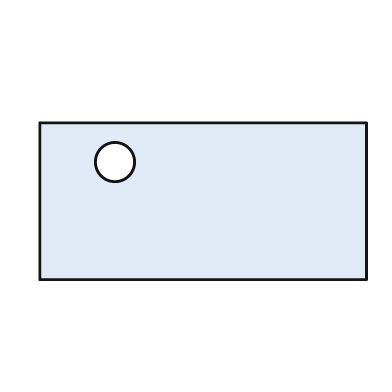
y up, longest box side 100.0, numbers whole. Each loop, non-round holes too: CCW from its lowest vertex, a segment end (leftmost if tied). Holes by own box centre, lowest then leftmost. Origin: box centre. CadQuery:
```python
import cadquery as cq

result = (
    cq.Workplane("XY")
    .moveTo(-50.0, -24.0)
    .lineTo(50.0, -24.0)
    .lineTo(50.0, 24.0)
    .lineTo(-50.0, 24.0)
    .close()
    .moveTo(-27.0, 12.0)
    .circle(6.0)
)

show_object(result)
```